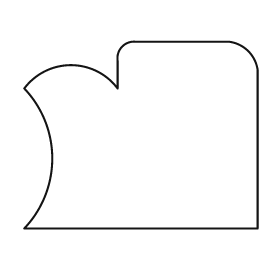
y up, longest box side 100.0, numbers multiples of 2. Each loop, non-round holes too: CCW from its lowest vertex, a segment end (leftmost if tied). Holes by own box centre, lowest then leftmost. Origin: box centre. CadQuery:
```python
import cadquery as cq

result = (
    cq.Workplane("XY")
    .moveTo(-50.0, -40.0)
    .lineTo(50.0, -40.0)
    .lineTo(50.0, 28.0)
    .threePointArc((46.0, 36.0), (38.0, 40.0))
    .lineTo(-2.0, 40.0)
    .threePointArc((-8.0, 38.0), (-10.0, 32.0))
    .lineTo(-10.0, 20.0)
    .threePointArc((-30.0, 30.0), (-50.0, 20.0))
    .threePointArc((-38.0, -10.0), (-50.0, -40.0))
    .close()
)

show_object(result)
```